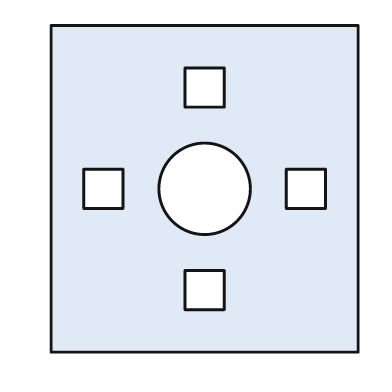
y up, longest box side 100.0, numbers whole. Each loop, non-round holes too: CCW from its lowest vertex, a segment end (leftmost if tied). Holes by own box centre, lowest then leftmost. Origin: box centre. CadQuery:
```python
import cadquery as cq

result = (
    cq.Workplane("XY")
    .moveTo(-47.0, -50.0)
    .lineTo(47.0, -50.0)
    .lineTo(47.0, 50.0)
    .lineTo(-47.0, 50.0)
    .close()
    .moveTo(-6.0, -37.0)
    .lineTo(6.0, -37.0)
    .lineTo(6.0, -25.0)
    .lineTo(-6.0, -25.0)
    .close()
    .moveTo(-37.0, -6.0)
    .lineTo(-25.0, -6.0)
    .lineTo(-25.0, 6.0)
    .lineTo(-37.0, 6.0)
    .close()
    .moveTo(0.0, 0.0)
    .circle(14.0)
    .moveTo(25.0, -6.0)
    .lineTo(37.0, -6.0)
    .lineTo(37.0, 6.0)
    .lineTo(25.0, 6.0)
    .close()
    .moveTo(-6.0, 25.0)
    .lineTo(6.0, 25.0)
    .lineTo(6.0, 37.0)
    .lineTo(-6.0, 37.0)
    .close()
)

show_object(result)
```